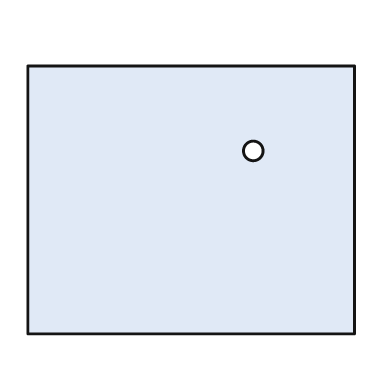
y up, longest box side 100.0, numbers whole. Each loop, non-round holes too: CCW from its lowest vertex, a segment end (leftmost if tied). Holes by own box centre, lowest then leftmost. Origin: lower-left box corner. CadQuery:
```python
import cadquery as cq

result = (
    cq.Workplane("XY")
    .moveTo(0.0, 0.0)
    .lineTo(100.0, 0.0)
    .lineTo(100.0, 82.0)
    .lineTo(0.0, 82.0)
    .close()
    .moveTo(69.0, 56.0)
    .circle(3.0)
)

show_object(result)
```